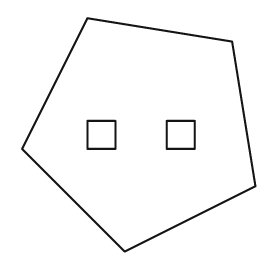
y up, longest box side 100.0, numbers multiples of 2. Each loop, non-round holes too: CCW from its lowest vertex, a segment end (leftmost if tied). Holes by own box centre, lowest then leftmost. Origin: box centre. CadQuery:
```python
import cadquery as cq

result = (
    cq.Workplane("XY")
    .moveTo(-6.0, -50.0)
    .lineTo(50.0, -22.0)
    .lineTo(40.0, 40.0)
    .lineTo(-22.0, 50.0)
    .lineTo(-50.0, -6.0)
    .close()
    .moveTo(-22.0, -6.0)
    .lineTo(-10.0, -6.0)
    .lineTo(-10.0, 6.0)
    .lineTo(-22.0, 6.0)
    .close()
    .moveTo(12.0, -6.0)
    .lineTo(24.0, -6.0)
    .lineTo(24.0, 6.0)
    .lineTo(12.0, 6.0)
    .close()
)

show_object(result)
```